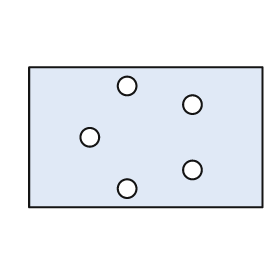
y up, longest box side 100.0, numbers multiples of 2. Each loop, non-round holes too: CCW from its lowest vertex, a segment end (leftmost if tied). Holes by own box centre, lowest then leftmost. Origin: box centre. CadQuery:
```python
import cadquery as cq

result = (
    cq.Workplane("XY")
    .moveTo(-50.0, -30.0)
    .lineTo(50.0, -30.0)
    .lineTo(50.0, 30.0)
    .lineTo(-50.0, 30.0)
    .close()
    .moveTo(-8.0, -22.0)
    .circle(4.0)
    .moveTo(20.0, -14.0)
    .circle(4.0)
    .moveTo(-24.0, 0.0)
    .circle(4.0)
    .moveTo(20.0, 14.0)
    .circle(4.0)
    .moveTo(-8.0, 22.0)
    .circle(4.0)
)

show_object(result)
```